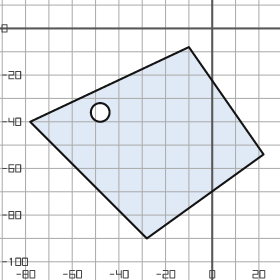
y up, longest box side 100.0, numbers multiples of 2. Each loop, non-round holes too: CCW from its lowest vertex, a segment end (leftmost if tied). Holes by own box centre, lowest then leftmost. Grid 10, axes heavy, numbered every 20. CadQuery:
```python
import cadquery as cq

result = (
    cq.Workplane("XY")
    .moveTo(-28.0, -90.0)
    .lineTo(22.0, -54.0)
    .lineTo(-10.0, -8.0)
    .lineTo(-78.0, -40.0)
    .close()
    .moveTo(-48.0, -36.0)
    .circle(4.0)
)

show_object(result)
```